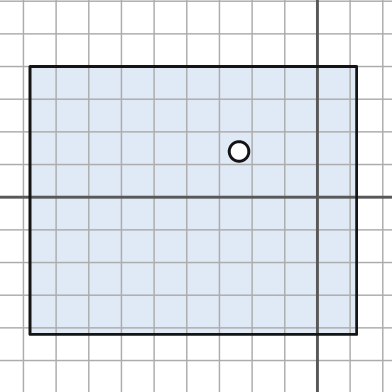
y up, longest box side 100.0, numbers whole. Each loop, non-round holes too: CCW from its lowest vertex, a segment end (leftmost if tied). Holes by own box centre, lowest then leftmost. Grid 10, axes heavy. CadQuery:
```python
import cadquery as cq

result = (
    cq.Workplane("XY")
    .moveTo(-88.0, -42.0)
    .lineTo(12.0, -42.0)
    .lineTo(12.0, 40.0)
    .lineTo(-88.0, 40.0)
    .close()
    .moveTo(-24.0, 14.0)
    .circle(3.0)
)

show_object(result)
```